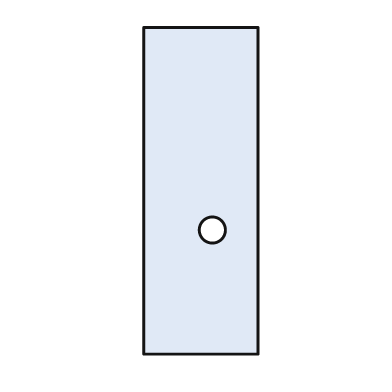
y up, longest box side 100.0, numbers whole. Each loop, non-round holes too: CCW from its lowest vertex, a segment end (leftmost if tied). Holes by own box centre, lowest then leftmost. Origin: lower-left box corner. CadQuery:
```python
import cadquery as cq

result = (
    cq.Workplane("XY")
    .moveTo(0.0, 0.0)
    .lineTo(35.0, 0.0)
    .lineTo(35.0, 100.0)
    .lineTo(0.0, 100.0)
    .close()
    .moveTo(21.0, 38.0)
    .circle(4.0)
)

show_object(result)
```